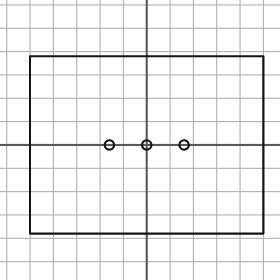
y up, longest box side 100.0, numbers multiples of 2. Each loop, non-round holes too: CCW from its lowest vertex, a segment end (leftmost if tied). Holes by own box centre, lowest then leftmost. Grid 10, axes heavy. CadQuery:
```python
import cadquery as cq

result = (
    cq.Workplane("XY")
    .moveTo(-50.0, -38.0)
    .lineTo(50.0, -38.0)
    .lineTo(50.0, 38.0)
    .lineTo(-50.0, 38.0)
    .close()
    .moveTo(-16.0, 0.0)
    .circle(2.0)
    .moveTo(0.0, 0.0)
    .circle(2.0)
    .moveTo(16.0, 0.0)
    .circle(2.0)
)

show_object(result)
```